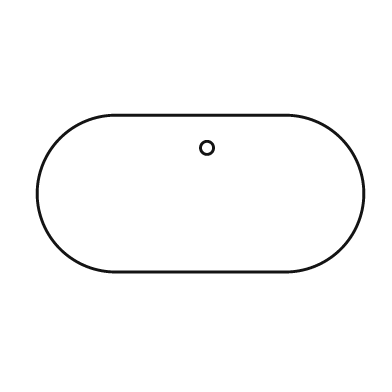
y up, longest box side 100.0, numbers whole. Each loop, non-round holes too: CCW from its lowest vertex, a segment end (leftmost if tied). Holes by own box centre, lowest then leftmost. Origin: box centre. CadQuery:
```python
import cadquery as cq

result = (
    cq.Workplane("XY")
    .moveTo(-26.0, -24.0)
    .lineTo(26.0, -24.0)
    .threePointArc((50.0, 0.0), (26.0, 24.0))
    .lineTo(-26.0, 24.0)
    .threePointArc((-50.0, 0.0), (-26.0, -24.0))
    .close()
    .moveTo(2.0, 14.0)
    .circle(2.0)
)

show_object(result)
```